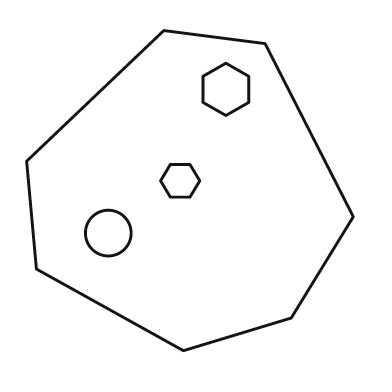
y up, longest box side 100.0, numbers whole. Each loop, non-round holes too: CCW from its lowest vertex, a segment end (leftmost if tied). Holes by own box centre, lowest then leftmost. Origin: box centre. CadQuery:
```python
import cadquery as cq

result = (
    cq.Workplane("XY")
    .moveTo(-2.0, -49.0)
    .lineTo(31.0, -39.0)
    .lineTo(50.0, -8.0)
    .lineTo(23.0, 45.0)
    .lineTo(-8.0, 49.0)
    .lineTo(-50.0, 9.0)
    .lineTo(-47.0, -24.0)
    .close()
    .moveTo(-25.0, -13.0)
    .circle(7.0)
    .moveTo(-6.0, -2.0)
    .lineTo(0.0, -2.0)
    .lineTo(3.0, 3.0)
    .lineTo(0.0, 8.0)
    .lineTo(-6.0, 8.0)
    .lineTo(-9.0, 3.0)
    .close()
    .moveTo(11.0, 23.0)
    .lineTo(18.0, 27.0)
    .lineTo(18.0, 35.0)
    .lineTo(11.0, 39.0)
    .lineTo(4.0, 35.0)
    .lineTo(4.0, 27.0)
    .close()
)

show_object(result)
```